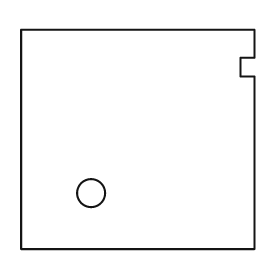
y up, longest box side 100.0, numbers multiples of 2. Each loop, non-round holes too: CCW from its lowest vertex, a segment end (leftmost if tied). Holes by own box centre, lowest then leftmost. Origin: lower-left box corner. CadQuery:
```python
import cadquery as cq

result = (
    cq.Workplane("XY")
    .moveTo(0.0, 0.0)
    .lineTo(100.0, 0.0)
    .lineTo(100.0, 74.0)
    .lineTo(94.0, 74.0)
    .lineTo(94.0, 82.0)
    .lineTo(100.0, 82.0)
    .lineTo(100.0, 94.0)
    .lineTo(0.0, 94.0)
    .close()
    .moveTo(30.0, 24.0)
    .circle(6.0)
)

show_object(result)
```